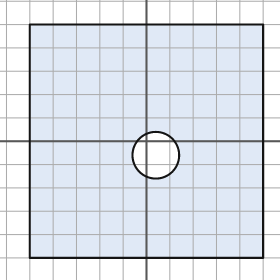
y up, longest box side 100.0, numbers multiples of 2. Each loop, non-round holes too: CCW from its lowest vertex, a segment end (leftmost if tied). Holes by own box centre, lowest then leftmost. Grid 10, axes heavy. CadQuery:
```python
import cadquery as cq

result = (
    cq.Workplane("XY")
    .moveTo(-50.0, -50.0)
    .lineTo(50.0, -50.0)
    .lineTo(50.0, 50.0)
    .lineTo(-50.0, 50.0)
    .close()
    .moveTo(4.0, -6.0)
    .circle(10.0)
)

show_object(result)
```